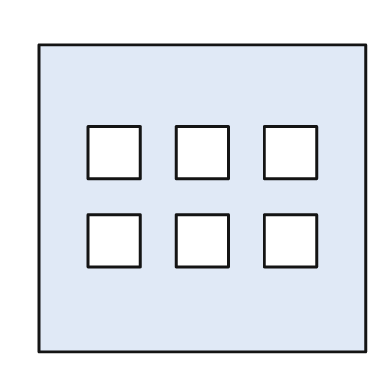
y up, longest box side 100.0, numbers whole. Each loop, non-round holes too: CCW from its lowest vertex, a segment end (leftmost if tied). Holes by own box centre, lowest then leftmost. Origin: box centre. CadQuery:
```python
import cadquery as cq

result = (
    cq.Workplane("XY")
    .moveTo(-50.0, -47.0)
    .lineTo(50.0, -47.0)
    .lineTo(50.0, 47.0)
    .lineTo(-50.0, 47.0)
    .close()
    .moveTo(-35.0, -21.0)
    .lineTo(-19.0, -21.0)
    .lineTo(-19.0, -5.0)
    .lineTo(-35.0, -5.0)
    .close()
    .moveTo(-8.0, -21.0)
    .lineTo(8.0, -21.0)
    .lineTo(8.0, -5.0)
    .lineTo(-8.0, -5.0)
    .close()
    .moveTo(19.0, -21.0)
    .lineTo(35.0, -21.0)
    .lineTo(35.0, -5.0)
    .lineTo(19.0, -5.0)
    .close()
    .moveTo(-35.0, 6.0)
    .lineTo(-19.0, 6.0)
    .lineTo(-19.0, 22.0)
    .lineTo(-35.0, 22.0)
    .close()
    .moveTo(-8.0, 6.0)
    .lineTo(8.0, 6.0)
    .lineTo(8.0, 22.0)
    .lineTo(-8.0, 22.0)
    .close()
    .moveTo(19.0, 6.0)
    .lineTo(35.0, 6.0)
    .lineTo(35.0, 22.0)
    .lineTo(19.0, 22.0)
    .close()
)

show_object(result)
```